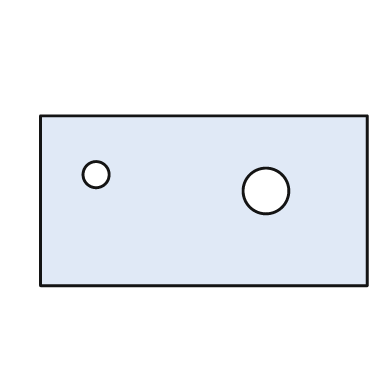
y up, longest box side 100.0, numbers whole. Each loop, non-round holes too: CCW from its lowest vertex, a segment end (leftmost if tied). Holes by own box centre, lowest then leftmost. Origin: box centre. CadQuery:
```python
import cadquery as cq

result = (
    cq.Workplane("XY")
    .moveTo(-50.0, -26.0)
    .lineTo(50.0, -26.0)
    .lineTo(50.0, 26.0)
    .lineTo(-50.0, 26.0)
    .close()
    .moveTo(19.0, 3.0)
    .circle(7.0)
    .moveTo(-33.0, 8.0)
    .circle(4.0)
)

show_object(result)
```